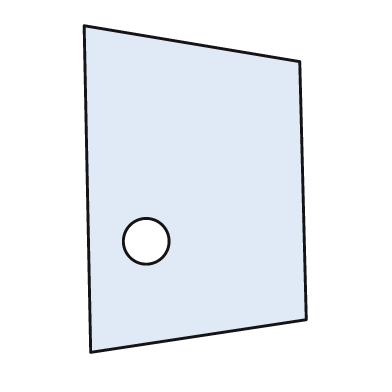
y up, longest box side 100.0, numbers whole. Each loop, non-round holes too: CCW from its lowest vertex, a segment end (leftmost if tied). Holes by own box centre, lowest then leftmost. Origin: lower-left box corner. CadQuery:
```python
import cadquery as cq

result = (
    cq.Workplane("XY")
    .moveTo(2.0, 0.0)
    .lineTo(68.0, 10.0)
    .lineTo(66.0, 89.0)
    .lineTo(0.0, 100.0)
    .close()
    .moveTo(19.0, 34.0)
    .circle(7.0)
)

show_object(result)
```